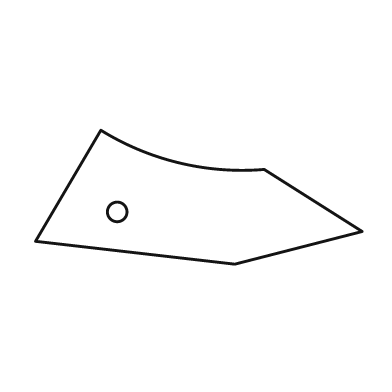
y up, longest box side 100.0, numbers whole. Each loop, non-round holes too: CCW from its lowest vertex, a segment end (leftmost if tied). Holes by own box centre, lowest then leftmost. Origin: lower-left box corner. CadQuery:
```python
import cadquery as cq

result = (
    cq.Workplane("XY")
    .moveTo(61.0, 0.0)
    .lineTo(100.0, 10.0)
    .lineTo(70.0, 29.0)
    .threePointArc((44.0, 31.0), (20.0, 41.0))
    .lineTo(0.0, 7.0)
    .close()
    .moveTo(25.0, 16.0)
    .circle(3.0)
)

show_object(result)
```